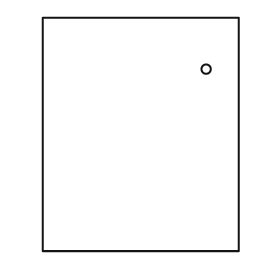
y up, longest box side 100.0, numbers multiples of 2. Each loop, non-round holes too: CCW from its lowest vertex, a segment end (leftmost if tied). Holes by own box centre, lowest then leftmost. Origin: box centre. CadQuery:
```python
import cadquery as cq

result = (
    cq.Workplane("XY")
    .moveTo(-42.0, -50.0)
    .lineTo(42.0, -50.0)
    .lineTo(42.0, 50.0)
    .lineTo(-42.0, 50.0)
    .close()
    .moveTo(28.0, 28.0)
    .circle(2.0)
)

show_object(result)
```